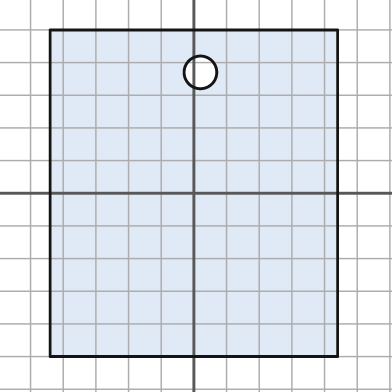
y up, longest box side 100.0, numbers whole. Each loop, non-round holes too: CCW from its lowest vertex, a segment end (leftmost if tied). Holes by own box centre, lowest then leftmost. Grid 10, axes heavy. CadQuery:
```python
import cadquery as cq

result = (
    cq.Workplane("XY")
    .moveTo(-44.0, -50.0)
    .lineTo(44.0, -50.0)
    .lineTo(44.0, 50.0)
    .lineTo(-44.0, 50.0)
    .close()
    .moveTo(2.0, 37.0)
    .circle(5.0)
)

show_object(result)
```